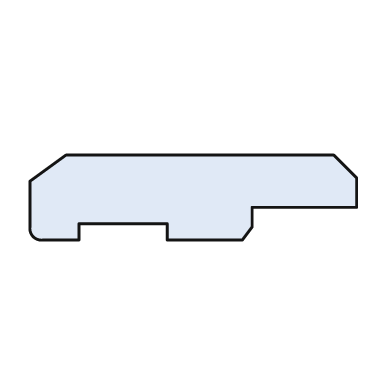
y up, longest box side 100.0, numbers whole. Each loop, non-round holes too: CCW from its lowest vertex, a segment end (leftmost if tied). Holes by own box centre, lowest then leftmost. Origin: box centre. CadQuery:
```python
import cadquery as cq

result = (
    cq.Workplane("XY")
    .moveTo(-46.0, -13.0)
    .lineTo(-35.0, -13.0)
    .lineTo(-35.0, -8.0)
    .lineTo(-8.0, -8.0)
    .lineTo(-8.0, -13.0)
    .lineTo(15.0, -13.0)
    .lineTo(18.0, -9.0)
    .lineTo(18.0, -3.0)
    .lineTo(50.0, -3.0)
    .lineTo(50.0, 6.0)
    .lineTo(43.0, 13.0)
    .lineTo(-39.0, 13.0)
    .lineTo(-50.0, 5.0)
    .lineTo(-50.0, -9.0)
    .threePointArc((-49.0, -12.0), (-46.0, -13.0))
    .close()
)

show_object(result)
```